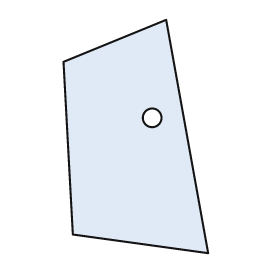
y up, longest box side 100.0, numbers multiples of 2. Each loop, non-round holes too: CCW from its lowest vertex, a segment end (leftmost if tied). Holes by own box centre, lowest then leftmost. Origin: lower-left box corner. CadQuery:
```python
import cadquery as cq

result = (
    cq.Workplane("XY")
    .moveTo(62.0, 0.0)
    .lineTo(44.0, 100.0)
    .lineTo(0.0, 82.0)
    .lineTo(4.0, 8.0)
    .close()
    .moveTo(38.0, 58.0)
    .circle(4.0)
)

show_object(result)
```